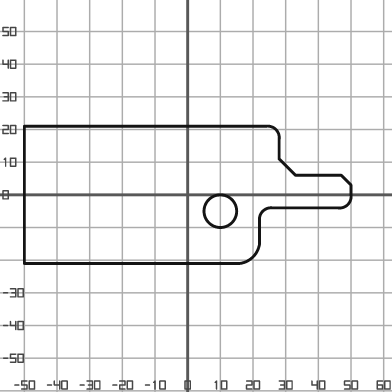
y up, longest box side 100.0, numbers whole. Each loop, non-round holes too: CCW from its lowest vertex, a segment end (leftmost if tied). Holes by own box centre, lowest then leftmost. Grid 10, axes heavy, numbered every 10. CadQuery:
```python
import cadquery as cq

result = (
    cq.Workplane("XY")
    .moveTo(-50.0, -21.0)
    .lineTo(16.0, -21.0)
    .threePointArc((20.0, -19.0), (22.0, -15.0))
    .lineTo(22.0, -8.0)
    .threePointArc((23.0, -5.0), (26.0, -4.0))
    .lineTo(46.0, -4.0)
    .threePointArc((49.0, -3.0), (50.0, 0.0))
    .lineTo(50.0, 3.0)
    .lineTo(47.0, 6.0)
    .lineTo(33.0, 6.0)
    .lineTo(28.0, 11.0)
    .lineTo(28.0, 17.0)
    .threePointArc((27.0, 20.0), (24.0, 21.0))
    .lineTo(-50.0, 21.0)
    .close()
    .moveTo(10.0, -5.0)
    .circle(5.0)
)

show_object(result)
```